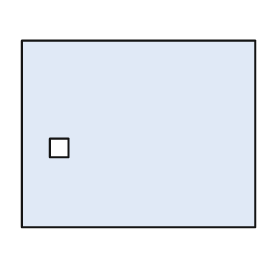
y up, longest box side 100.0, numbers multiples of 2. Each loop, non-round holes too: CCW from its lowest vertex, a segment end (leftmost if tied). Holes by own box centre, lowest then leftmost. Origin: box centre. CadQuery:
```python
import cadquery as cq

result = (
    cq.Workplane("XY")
    .moveTo(-50.0, -40.0)
    .lineTo(50.0, -40.0)
    .lineTo(50.0, 40.0)
    .lineTo(-50.0, 40.0)
    .close()
    .moveTo(-38.0, -10.0)
    .lineTo(-30.0, -10.0)
    .lineTo(-30.0, -2.0)
    .lineTo(-38.0, -2.0)
    .close()
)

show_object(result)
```